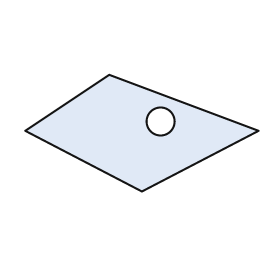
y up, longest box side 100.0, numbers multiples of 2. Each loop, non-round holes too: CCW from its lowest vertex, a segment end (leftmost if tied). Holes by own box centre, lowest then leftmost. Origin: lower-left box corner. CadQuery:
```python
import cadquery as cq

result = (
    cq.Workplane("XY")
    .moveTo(50.0, 0.0)
    .lineTo(100.0, 26.0)
    .lineTo(36.0, 50.0)
    .lineTo(0.0, 26.0)
    .close()
    .moveTo(58.0, 30.0)
    .circle(6.0)
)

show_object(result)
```